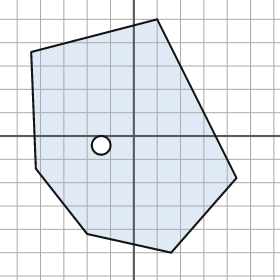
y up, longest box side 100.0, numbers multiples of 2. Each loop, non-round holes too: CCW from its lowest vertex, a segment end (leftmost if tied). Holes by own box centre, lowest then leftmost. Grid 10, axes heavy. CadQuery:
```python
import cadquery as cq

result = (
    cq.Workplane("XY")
    .moveTo(16.0, -50.0)
    .lineTo(44.0, -18.0)
    .lineTo(10.0, 50.0)
    .lineTo(-44.0, 36.0)
    .lineTo(-42.0, -14.0)
    .lineTo(-20.0, -42.0)
    .close()
    .moveTo(-14.0, -4.0)
    .circle(4.0)
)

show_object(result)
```